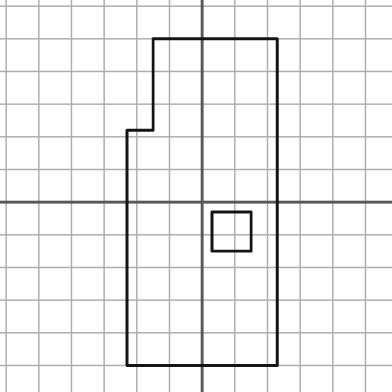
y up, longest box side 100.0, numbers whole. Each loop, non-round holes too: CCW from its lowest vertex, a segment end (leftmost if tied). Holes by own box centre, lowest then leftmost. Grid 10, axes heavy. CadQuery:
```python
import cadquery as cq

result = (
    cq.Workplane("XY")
    .moveTo(-23.0, -50.0)
    .lineTo(23.0, -50.0)
    .lineTo(23.0, 50.0)
    .lineTo(-15.0, 50.0)
    .lineTo(-15.0, 22.0)
    .lineTo(-23.0, 22.0)
    .close()
    .moveTo(3.0, -15.0)
    .lineTo(15.0, -15.0)
    .lineTo(15.0, -3.0)
    .lineTo(3.0, -3.0)
    .close()
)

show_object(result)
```